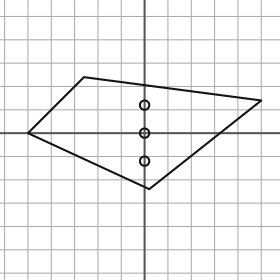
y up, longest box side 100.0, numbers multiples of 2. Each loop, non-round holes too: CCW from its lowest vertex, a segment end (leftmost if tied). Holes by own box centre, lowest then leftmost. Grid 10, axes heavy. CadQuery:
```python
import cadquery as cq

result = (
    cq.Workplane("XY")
    .moveTo(2.0, -24.0)
    .lineTo(50.0, 14.0)
    .lineTo(-26.0, 24.0)
    .lineTo(-50.0, 0.0)
    .close()
    .moveTo(0.0, -12.0)
    .circle(2.0)
    .moveTo(0.0, 0.0)
    .circle(2.0)
    .moveTo(0.0, 12.0)
    .circle(2.0)
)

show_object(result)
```